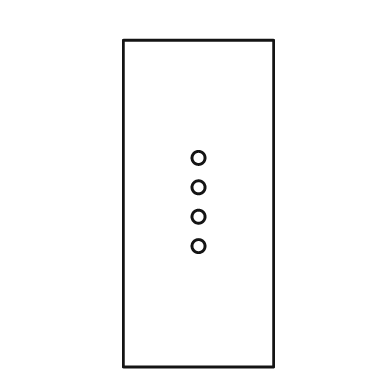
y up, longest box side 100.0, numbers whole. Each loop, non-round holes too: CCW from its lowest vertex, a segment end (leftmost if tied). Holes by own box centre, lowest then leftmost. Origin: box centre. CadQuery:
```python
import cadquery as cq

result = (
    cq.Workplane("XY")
    .moveTo(-23.0, -50.0)
    .lineTo(23.0, -50.0)
    .lineTo(23.0, 50.0)
    .lineTo(-23.0, 50.0)
    .close()
    .moveTo(0.0, -13.0)
    .circle(2.0)
    .moveTo(0.0, -4.0)
    .circle(2.0)
    .moveTo(0.0, 5.0)
    .circle(2.0)
    .moveTo(0.0, 14.0)
    .circle(2.0)
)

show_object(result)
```